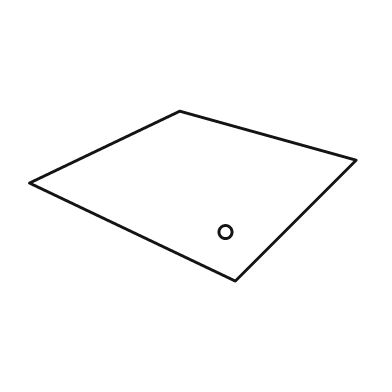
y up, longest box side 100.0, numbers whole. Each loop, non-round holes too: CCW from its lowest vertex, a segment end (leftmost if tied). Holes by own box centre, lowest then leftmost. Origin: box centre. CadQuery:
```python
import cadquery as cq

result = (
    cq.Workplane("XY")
    .moveTo(13.0, -26.0)
    .lineTo(50.0, 11.0)
    .lineTo(-4.0, 26.0)
    .lineTo(-50.0, 4.0)
    .close()
    .moveTo(10.0, -11.0)
    .circle(2.0)
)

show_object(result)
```